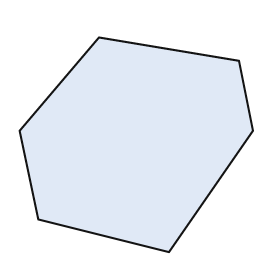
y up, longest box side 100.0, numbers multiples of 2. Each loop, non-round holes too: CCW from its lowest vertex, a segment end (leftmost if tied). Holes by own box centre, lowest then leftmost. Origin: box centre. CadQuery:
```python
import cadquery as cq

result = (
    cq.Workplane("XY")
    .moveTo(14.0, -46.0)
    .lineTo(50.0, 6.0)
    .lineTo(44.0, 36.0)
    .lineTo(-16.0, 46.0)
    .lineTo(-50.0, 6.0)
    .lineTo(-42.0, -32.0)
    .close()
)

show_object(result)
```